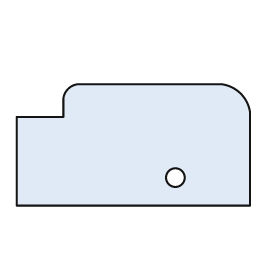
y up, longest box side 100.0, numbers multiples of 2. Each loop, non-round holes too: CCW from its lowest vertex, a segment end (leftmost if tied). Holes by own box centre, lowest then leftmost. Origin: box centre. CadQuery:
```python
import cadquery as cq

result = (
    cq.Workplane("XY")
    .moveTo(-50.0, -26.0)
    .lineTo(50.0, -26.0)
    .lineTo(50.0, 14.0)
    .threePointArc((46.0, 22.0), (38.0, 26.0))
    .lineTo(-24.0, 26.0)
    .threePointArc((-28.0, 24.0), (-30.0, 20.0))
    .lineTo(-30.0, 12.0)
    .lineTo(-50.0, 12.0)
    .close()
    .moveTo(18.0, -14.0)
    .circle(4.0)
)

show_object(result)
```